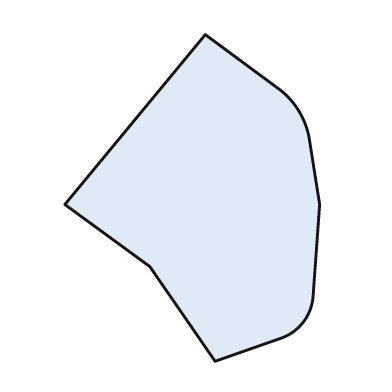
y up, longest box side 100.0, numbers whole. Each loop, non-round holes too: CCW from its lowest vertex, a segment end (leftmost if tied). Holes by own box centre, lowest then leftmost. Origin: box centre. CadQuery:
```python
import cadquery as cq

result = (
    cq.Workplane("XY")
    .moveTo(7.0, -50.0)
    .lineTo(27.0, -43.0)
    .threePointArc((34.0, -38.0), (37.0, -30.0))
    .lineTo(39.0, -2.0)
    .lineTo(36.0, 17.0)
    .threePointArc((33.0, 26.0), (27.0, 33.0))
    .lineTo(4.0, 50.0)
    .lineTo(-39.0, -2.0)
    .lineTo(-13.0, -21.0)
    .close()
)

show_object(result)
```